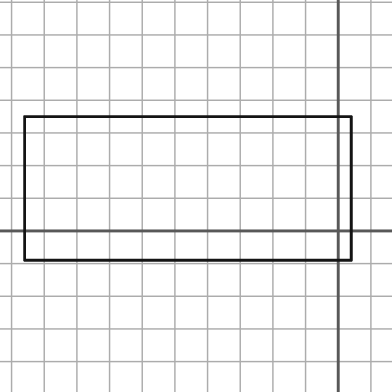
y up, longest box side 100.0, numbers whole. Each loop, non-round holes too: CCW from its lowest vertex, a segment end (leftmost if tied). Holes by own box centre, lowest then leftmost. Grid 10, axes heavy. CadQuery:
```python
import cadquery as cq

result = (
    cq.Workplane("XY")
    .moveTo(-96.0, -9.0)
    .lineTo(4.0, -9.0)
    .lineTo(4.0, 35.0)
    .lineTo(-96.0, 35.0)
    .close()
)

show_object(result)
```